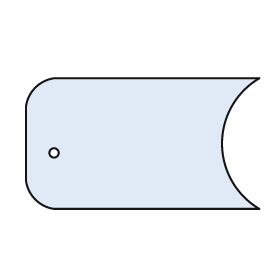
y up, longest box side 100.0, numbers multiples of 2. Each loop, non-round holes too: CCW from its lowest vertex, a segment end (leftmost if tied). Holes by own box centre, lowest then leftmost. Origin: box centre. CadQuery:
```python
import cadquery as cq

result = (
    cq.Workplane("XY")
    .moveTo(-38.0, -28.0)
    .lineTo(50.0, -28.0)
    .threePointArc((34.0, 0.0), (50.0, 28.0))
    .lineTo(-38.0, 28.0)
    .threePointArc((-46.0, 24.0), (-50.0, 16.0))
    .lineTo(-50.0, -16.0)
    .threePointArc((-46.0, -24.0), (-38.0, -28.0))
    .close()
    .moveTo(-38.0, -4.0)
    .circle(2.0)
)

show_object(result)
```